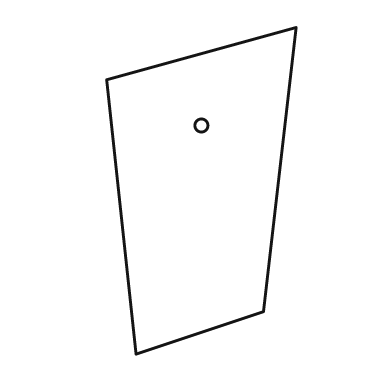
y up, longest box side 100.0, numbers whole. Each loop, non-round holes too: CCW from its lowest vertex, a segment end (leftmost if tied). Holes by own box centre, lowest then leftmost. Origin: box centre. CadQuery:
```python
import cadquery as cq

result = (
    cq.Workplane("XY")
    .moveTo(-20.0, -50.0)
    .lineTo(19.0, -37.0)
    .lineTo(29.0, 50.0)
    .lineTo(-29.0, 34.0)
    .close()
    .moveTo(0.0, 20.0)
    .circle(2.0)
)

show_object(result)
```